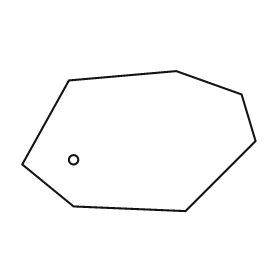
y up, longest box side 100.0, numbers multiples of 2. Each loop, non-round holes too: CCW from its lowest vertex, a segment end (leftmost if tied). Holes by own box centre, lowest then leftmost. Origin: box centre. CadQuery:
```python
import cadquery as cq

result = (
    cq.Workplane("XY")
    .moveTo(20.0, -30.0)
    .lineTo(50.0, 0.0)
    .lineTo(44.0, 20.0)
    .lineTo(16.0, 30.0)
    .lineTo(-30.0, 26.0)
    .lineTo(-50.0, -10.0)
    .lineTo(-28.0, -28.0)
    .close()
    .moveTo(-28.0, -8.0)
    .circle(2.0)
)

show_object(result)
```